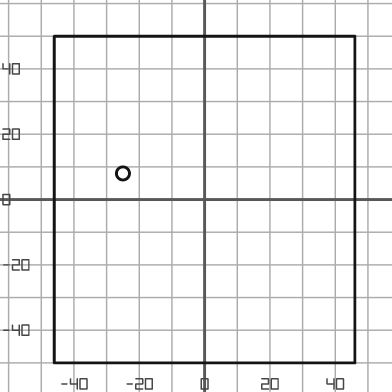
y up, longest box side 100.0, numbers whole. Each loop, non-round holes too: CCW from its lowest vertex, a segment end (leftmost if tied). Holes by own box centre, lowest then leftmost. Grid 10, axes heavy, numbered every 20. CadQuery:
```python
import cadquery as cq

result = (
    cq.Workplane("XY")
    .moveTo(-46.0, -50.0)
    .lineTo(46.0, -50.0)
    .lineTo(46.0, 50.0)
    .lineTo(-46.0, 50.0)
    .close()
    .moveTo(-25.0, 8.0)
    .circle(2.0)
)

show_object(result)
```